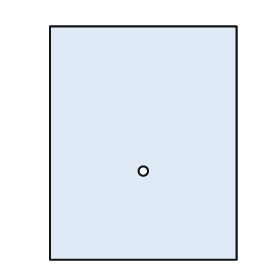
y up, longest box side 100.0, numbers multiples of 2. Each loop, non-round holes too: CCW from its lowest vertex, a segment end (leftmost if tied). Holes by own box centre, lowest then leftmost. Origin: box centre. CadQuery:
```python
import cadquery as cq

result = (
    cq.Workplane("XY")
    .moveTo(-40.0, -50.0)
    .lineTo(40.0, -50.0)
    .lineTo(40.0, 50.0)
    .lineTo(-40.0, 50.0)
    .close()
    .moveTo(0.0, -12.0)
    .circle(2.0)
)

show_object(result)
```